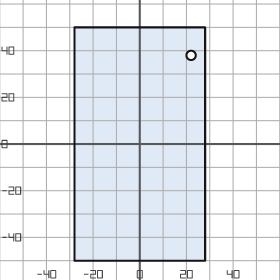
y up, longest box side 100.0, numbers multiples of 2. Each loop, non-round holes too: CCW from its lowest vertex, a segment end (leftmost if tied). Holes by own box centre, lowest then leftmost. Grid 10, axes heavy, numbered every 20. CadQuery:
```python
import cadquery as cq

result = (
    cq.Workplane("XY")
    .moveTo(-28.0, -50.0)
    .lineTo(28.0, -50.0)
    .lineTo(28.0, 50.0)
    .lineTo(-28.0, 50.0)
    .close()
    .moveTo(22.0, 38.0)
    .circle(2.0)
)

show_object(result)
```